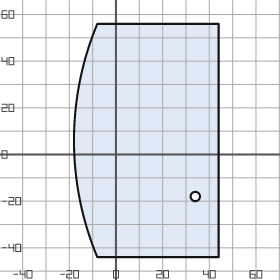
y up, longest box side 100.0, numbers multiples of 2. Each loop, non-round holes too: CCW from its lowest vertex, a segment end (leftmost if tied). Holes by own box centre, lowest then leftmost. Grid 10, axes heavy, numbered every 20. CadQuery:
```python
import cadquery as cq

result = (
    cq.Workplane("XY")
    .moveTo(-8.0, -44.0)
    .lineTo(44.0, -44.0)
    .lineTo(44.0, 56.0)
    .lineTo(-8.0, 56.0)
    .threePointArc((-18.0, 6.0), (-8.0, -44.0))
    .close()
    .moveTo(34.0, -18.0)
    .circle(2.0)
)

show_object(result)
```